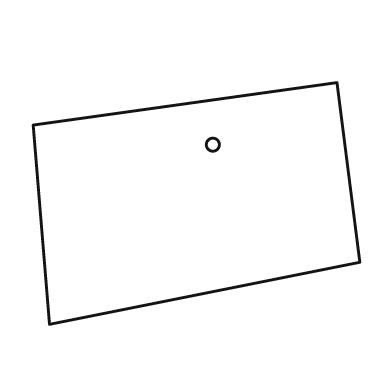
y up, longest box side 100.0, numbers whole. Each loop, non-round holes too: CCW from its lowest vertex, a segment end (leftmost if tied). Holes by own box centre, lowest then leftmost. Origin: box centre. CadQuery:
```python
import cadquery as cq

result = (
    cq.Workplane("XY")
    .moveTo(-45.0, -37.0)
    .lineTo(50.0, -18.0)
    .lineTo(43.0, 37.0)
    .lineTo(-50.0, 24.0)
    .close()
    .moveTo(5.0, 18.0)
    .circle(2.0)
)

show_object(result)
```